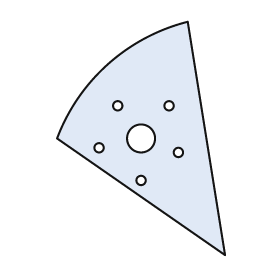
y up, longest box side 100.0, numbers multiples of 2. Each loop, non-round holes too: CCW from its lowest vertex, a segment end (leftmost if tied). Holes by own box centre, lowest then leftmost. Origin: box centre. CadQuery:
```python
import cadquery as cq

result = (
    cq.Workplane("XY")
    .moveTo(36.0, -50.0)
    .lineTo(20.0, 50.0)
    .threePointArc((-14.0, 32.0), (-36.0, 0.0))
    .close()
    .moveTo(0.0, -18.0)
    .circle(2.0)
    .moveTo(16.0, -6.0)
    .circle(2.0)
    .moveTo(-18.0, -4.0)
    .circle(2.0)
    .moveTo(0.0, 0.0)
    .circle(6.0)
    .moveTo(-10.0, 14.0)
    .circle(2.0)
    .moveTo(12.0, 14.0)
    .circle(2.0)
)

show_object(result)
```